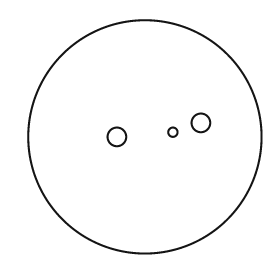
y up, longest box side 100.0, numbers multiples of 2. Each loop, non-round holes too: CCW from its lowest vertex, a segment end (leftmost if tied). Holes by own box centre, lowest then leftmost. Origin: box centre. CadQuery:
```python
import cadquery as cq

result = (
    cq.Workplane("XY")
    .moveTo(0.0, 0.0)
    .circle(50.0)
    .moveTo(-12.0, 0.0)
    .circle(4.0)
    .moveTo(12.0, 2.0)
    .circle(2.0)
    .moveTo(24.0, 6.0)
    .circle(4.0)
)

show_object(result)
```